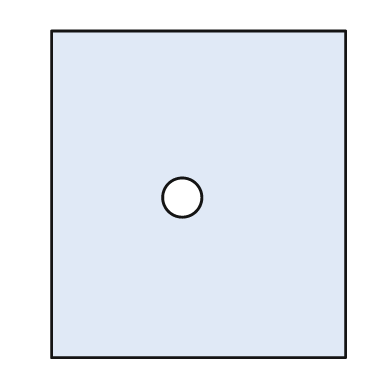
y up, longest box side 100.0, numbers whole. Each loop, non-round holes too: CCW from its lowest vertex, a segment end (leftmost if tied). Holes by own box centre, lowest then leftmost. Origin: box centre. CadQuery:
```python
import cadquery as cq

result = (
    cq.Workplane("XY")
    .moveTo(-45.0, -50.0)
    .lineTo(45.0, -50.0)
    .lineTo(45.0, 50.0)
    .lineTo(-45.0, 50.0)
    .close()
    .moveTo(-5.0, -1.0)
    .circle(6.0)
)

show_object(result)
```